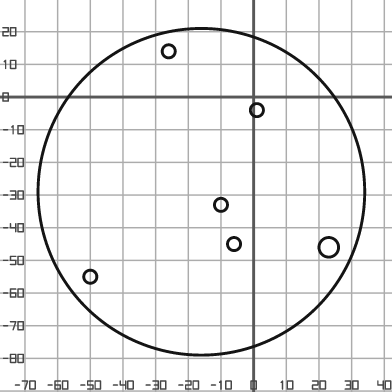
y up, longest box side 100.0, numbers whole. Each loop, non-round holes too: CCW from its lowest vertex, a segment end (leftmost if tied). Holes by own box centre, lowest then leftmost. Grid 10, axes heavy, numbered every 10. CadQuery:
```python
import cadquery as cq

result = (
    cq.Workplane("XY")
    .moveTo(-16.0, -29.0)
    .circle(50.0)
    .moveTo(-50.0, -55.0)
    .circle(2.0)
    .moveTo(23.0, -46.0)
    .circle(3.0)
    .moveTo(-6.0, -45.0)
    .circle(2.0)
    .moveTo(-10.0, -33.0)
    .circle(2.0)
    .moveTo(1.0, -4.0)
    .circle(2.0)
    .moveTo(-26.0, 14.0)
    .circle(2.0)
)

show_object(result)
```